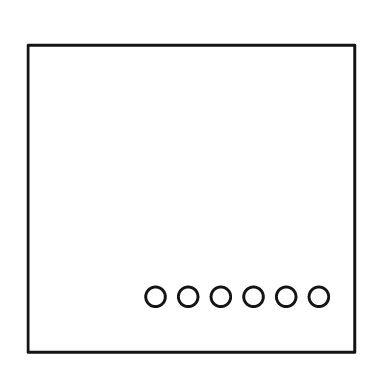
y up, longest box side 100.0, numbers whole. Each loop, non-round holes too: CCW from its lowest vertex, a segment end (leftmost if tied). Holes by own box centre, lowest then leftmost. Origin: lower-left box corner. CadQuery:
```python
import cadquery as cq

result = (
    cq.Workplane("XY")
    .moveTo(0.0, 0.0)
    .lineTo(100.0, 0.0)
    .lineTo(100.0, 94.0)
    .lineTo(0.0, 94.0)
    .close()
    .moveTo(39.0, 17.0)
    .circle(3.0)
    .moveTo(49.0, 17.0)
    .circle(3.0)
    .moveTo(59.0, 17.0)
    .circle(3.0)
    .moveTo(69.0, 17.0)
    .circle(3.0)
    .moveTo(79.0, 17.0)
    .circle(3.0)
    .moveTo(89.0, 17.0)
    .circle(3.0)
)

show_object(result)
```